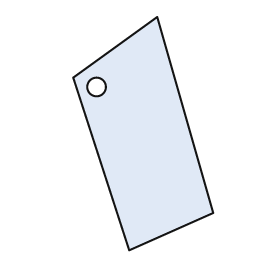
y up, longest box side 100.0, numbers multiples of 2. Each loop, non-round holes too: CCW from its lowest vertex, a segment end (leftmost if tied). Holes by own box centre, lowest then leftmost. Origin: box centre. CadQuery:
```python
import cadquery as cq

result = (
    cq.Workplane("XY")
    .moveTo(-6.0, -50.0)
    .lineTo(30.0, -34.0)
    .lineTo(6.0, 50.0)
    .lineTo(-30.0, 24.0)
    .close()
    .moveTo(-20.0, 20.0)
    .circle(4.0)
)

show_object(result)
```